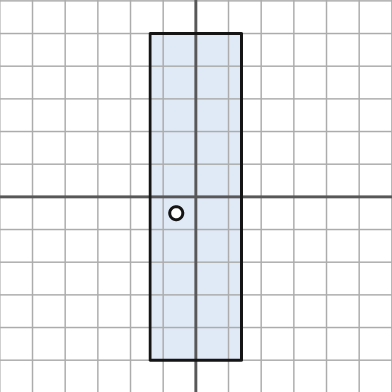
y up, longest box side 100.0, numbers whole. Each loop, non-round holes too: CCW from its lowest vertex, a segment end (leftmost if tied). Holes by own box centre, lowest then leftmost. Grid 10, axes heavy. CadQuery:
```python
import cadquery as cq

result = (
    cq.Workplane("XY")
    .moveTo(-14.0, -50.0)
    .lineTo(14.0, -50.0)
    .lineTo(14.0, 50.0)
    .lineTo(-14.0, 50.0)
    .close()
    .moveTo(-6.0, -5.0)
    .circle(2.0)
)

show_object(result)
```